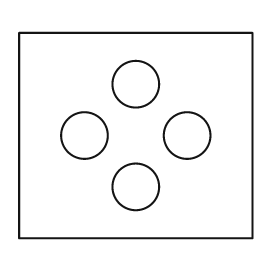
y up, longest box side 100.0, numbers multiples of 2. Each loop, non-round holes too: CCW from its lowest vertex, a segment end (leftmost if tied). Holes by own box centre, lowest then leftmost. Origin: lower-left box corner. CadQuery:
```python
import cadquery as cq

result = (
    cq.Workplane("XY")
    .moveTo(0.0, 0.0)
    .lineTo(100.0, 0.0)
    .lineTo(100.0, 88.0)
    .lineTo(0.0, 88.0)
    .close()
    .moveTo(50.0, 22.0)
    .circle(10.0)
    .moveTo(28.0, 44.0)
    .circle(10.0)
    .moveTo(72.0, 44.0)
    .circle(10.0)
    .moveTo(50.0, 66.0)
    .circle(10.0)
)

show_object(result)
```